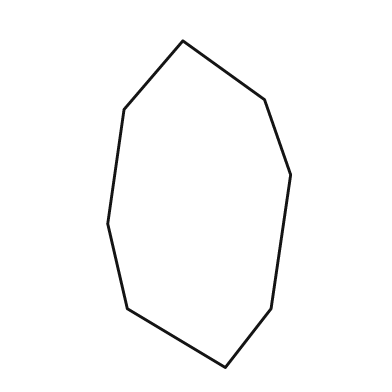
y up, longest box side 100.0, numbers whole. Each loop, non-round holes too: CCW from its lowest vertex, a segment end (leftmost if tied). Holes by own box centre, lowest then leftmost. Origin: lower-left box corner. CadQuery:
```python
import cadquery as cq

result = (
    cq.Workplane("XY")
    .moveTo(36.0, 0.0)
    .lineTo(50.0, 18.0)
    .lineTo(56.0, 59.0)
    .lineTo(48.0, 82.0)
    .lineTo(23.0, 100.0)
    .lineTo(5.0, 79.0)
    .lineTo(0.0, 44.0)
    .lineTo(6.0, 18.0)
    .close()
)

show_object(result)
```